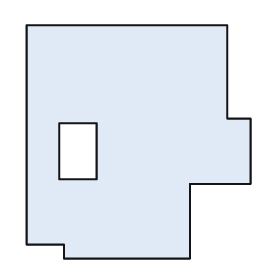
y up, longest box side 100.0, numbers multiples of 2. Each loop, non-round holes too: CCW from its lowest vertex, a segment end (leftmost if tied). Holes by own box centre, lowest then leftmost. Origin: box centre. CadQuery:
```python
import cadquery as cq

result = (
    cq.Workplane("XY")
    .moveTo(-32.0, -50.0)
    .lineTo(22.0, -50.0)
    .lineTo(22.0, -18.0)
    .lineTo(48.0, -18.0)
    .lineTo(48.0, 10.0)
    .lineTo(38.0, 10.0)
    .lineTo(38.0, 50.0)
    .lineTo(-48.0, 50.0)
    .lineTo(-48.0, -44.0)
    .lineTo(-32.0, -44.0)
    .close()
    .moveTo(-34.0, -16.0)
    .lineTo(-18.0, -16.0)
    .lineTo(-18.0, 8.0)
    .lineTo(-34.0, 8.0)
    .close()
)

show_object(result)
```